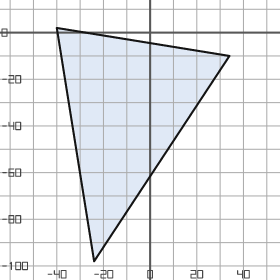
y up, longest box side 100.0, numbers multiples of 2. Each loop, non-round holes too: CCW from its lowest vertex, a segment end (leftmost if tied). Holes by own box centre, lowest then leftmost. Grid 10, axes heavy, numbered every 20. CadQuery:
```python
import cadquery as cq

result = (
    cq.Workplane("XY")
    .moveTo(-24.0, -98.0)
    .lineTo(34.0, -10.0)
    .lineTo(-40.0, 2.0)
    .close()
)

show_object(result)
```